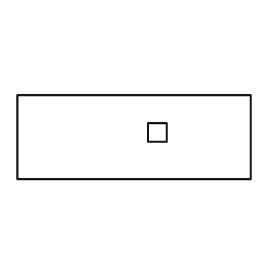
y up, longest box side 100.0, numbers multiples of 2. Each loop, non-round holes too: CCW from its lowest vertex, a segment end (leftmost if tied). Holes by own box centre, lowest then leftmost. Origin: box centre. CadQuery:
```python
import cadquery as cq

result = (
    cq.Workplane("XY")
    .moveTo(-50.0, -18.0)
    .lineTo(50.0, -18.0)
    .lineTo(50.0, 18.0)
    .lineTo(-50.0, 18.0)
    .close()
    .moveTo(6.0, -2.0)
    .lineTo(14.0, -2.0)
    .lineTo(14.0, 6.0)
    .lineTo(6.0, 6.0)
    .close()
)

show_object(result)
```